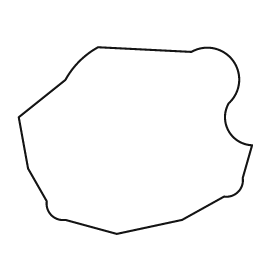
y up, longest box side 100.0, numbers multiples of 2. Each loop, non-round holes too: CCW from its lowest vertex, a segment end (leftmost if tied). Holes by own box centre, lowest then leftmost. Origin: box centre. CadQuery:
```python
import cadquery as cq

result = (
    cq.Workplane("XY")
    .moveTo(-8.0, -40.0)
    .lineTo(20.0, -34.0)
    .lineTo(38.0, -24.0)
    .threePointArc((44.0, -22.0), (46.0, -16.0))
    .lineTo(50.0, -2.0)
    .threePointArc((40.0, 4.0), (40.0, 16.0))
    .threePointArc((42.0, 34.0), (24.0, 38.0))
    .lineTo(-16.0, 40.0)
    .threePointArc((-24.0, 34.0), (-30.0, 26.0))
    .lineTo(-50.0, 10.0)
    .lineTo(-46.0, -12.0)
    .lineTo(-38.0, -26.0)
    .threePointArc((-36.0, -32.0), (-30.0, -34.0))
    .close()
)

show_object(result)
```